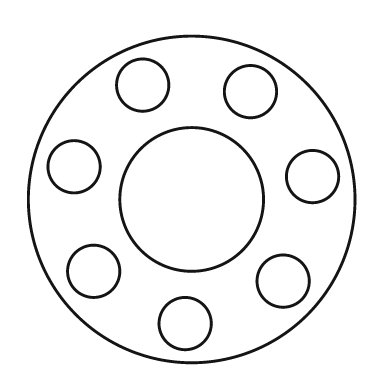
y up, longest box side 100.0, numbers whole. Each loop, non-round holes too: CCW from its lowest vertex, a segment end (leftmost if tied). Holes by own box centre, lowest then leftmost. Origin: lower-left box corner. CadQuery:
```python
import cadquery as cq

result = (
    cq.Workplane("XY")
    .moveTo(50.0, 50.0)
    .circle(50.0)
    .moveTo(48.0, 12.0)
    .circle(8.0)
    .moveTo(78.0, 25.0)
    .circle(8.0)
    .moveTo(20.0, 28.0)
    .circle(8.0)
    .moveTo(50.0, 50.0)
    .circle(22.0)
    .moveTo(87.0, 57.0)
    .circle(8.0)
    .moveTo(14.0, 60.0)
    .circle(8.0)
    .moveTo(68.0, 83.0)
    .circle(8.0)
    .moveTo(35.0, 85.0)
    .circle(8.0)
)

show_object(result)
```